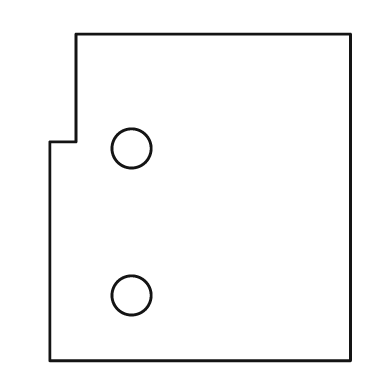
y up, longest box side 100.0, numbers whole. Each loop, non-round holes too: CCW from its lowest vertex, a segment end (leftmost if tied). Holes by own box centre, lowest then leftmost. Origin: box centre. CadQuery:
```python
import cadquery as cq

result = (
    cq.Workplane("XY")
    .moveTo(-46.0, -50.0)
    .lineTo(46.0, -50.0)
    .lineTo(46.0, 50.0)
    .lineTo(-38.0, 50.0)
    .lineTo(-38.0, 17.0)
    .lineTo(-46.0, 17.0)
    .close()
    .moveTo(-21.0, -30.0)
    .circle(6.0)
    .moveTo(-21.0, 15.0)
    .circle(6.0)
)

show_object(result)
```